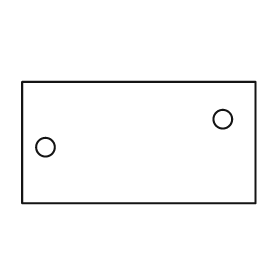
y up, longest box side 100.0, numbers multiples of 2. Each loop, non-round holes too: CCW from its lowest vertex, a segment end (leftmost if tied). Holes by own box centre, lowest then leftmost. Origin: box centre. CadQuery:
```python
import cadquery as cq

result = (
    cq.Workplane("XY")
    .moveTo(-50.0, -26.0)
    .lineTo(50.0, -26.0)
    .lineTo(50.0, 26.0)
    .lineTo(-50.0, 26.0)
    .close()
    .moveTo(-40.0, -2.0)
    .circle(4.0)
    .moveTo(36.0, 10.0)
    .circle(4.0)
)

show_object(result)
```